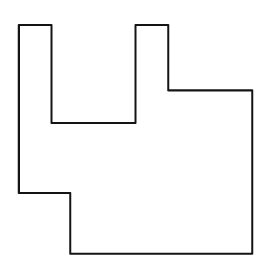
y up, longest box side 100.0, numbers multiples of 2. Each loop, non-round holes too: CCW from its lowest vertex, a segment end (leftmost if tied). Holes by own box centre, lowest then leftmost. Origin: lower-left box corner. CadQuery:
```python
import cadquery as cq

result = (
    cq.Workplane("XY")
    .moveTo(22.0, 0.0)
    .lineTo(100.0, 0.0)
    .lineTo(100.0, 70.0)
    .lineTo(64.0, 70.0)
    .lineTo(64.0, 98.0)
    .lineTo(50.0, 98.0)
    .lineTo(50.0, 56.0)
    .lineTo(14.0, 56.0)
    .lineTo(14.0, 98.0)
    .lineTo(0.0, 98.0)
    .lineTo(0.0, 26.0)
    .lineTo(22.0, 26.0)
    .close()
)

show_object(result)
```